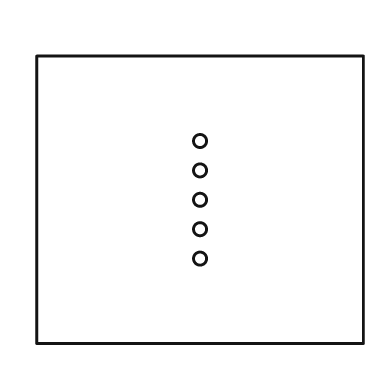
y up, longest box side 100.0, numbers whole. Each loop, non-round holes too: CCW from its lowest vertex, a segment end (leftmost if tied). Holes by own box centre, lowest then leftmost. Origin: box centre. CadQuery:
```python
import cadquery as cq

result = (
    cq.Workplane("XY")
    .moveTo(-50.0, -44.0)
    .lineTo(50.0, -44.0)
    .lineTo(50.0, 44.0)
    .lineTo(-50.0, 44.0)
    .close()
    .moveTo(0.0, -18.0)
    .circle(2.0)
    .moveTo(0.0, -9.0)
    .circle(2.0)
    .moveTo(0.0, 0.0)
    .circle(2.0)
    .moveTo(0.0, 9.0)
    .circle(2.0)
    .moveTo(0.0, 18.0)
    .circle(2.0)
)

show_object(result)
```